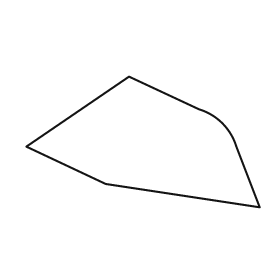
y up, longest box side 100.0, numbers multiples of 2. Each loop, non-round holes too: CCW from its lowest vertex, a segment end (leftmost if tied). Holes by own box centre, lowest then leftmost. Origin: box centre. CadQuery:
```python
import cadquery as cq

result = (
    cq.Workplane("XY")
    .moveTo(50.0, -28.0)
    .lineTo(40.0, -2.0)
    .threePointArc((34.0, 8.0), (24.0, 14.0))
    .lineTo(-6.0, 28.0)
    .lineTo(-50.0, -2.0)
    .lineTo(-16.0, -18.0)
    .close()
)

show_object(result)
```